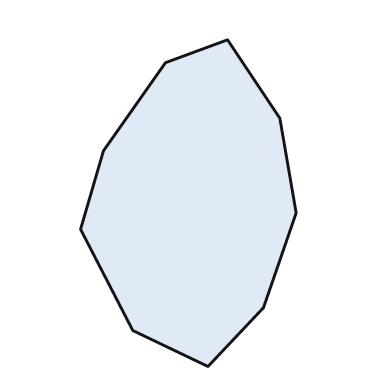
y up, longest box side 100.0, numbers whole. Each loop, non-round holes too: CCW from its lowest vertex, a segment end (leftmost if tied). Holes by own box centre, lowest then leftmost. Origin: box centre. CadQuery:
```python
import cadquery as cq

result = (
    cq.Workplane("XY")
    .moveTo(6.0, -50.0)
    .lineTo(23.0, -32.0)
    .lineTo(33.0, -3.0)
    .lineTo(28.0, 26.0)
    .lineTo(12.0, 50.0)
    .lineTo(-7.0, 43.0)
    .lineTo(-26.0, 16.0)
    .lineTo(-33.0, -8.0)
    .lineTo(-17.0, -39.0)
    .close()
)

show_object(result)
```